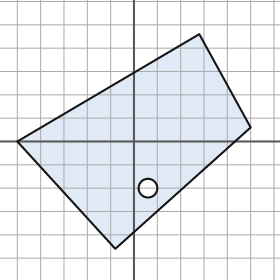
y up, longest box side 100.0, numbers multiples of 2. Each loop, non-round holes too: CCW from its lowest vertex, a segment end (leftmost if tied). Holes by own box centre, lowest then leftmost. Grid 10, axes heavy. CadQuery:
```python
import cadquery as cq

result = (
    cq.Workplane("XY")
    .moveTo(-8.0, -46.0)
    .lineTo(50.0, 6.0)
    .lineTo(28.0, 46.0)
    .lineTo(-50.0, 0.0)
    .close()
    .moveTo(6.0, -20.0)
    .circle(4.0)
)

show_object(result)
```